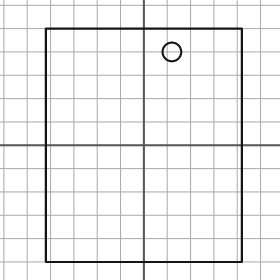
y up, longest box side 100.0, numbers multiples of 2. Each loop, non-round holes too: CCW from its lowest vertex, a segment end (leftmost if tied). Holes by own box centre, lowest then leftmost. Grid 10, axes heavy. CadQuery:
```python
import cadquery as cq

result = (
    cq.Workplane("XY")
    .moveTo(-42.0, -50.0)
    .lineTo(42.0, -50.0)
    .lineTo(42.0, 50.0)
    .lineTo(-42.0, 50.0)
    .close()
    .moveTo(12.0, 40.0)
    .circle(4.0)
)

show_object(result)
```